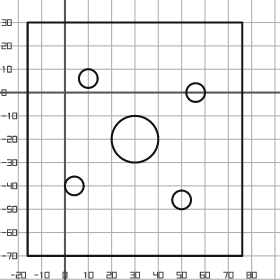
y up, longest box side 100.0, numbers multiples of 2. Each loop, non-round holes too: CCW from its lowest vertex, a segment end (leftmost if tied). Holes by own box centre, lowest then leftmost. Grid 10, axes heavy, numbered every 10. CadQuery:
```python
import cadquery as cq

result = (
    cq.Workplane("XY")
    .moveTo(-16.0, -70.0)
    .lineTo(76.0, -70.0)
    .lineTo(76.0, 30.0)
    .lineTo(-16.0, 30.0)
    .close()
    .moveTo(50.0, -46.0)
    .circle(4.0)
    .moveTo(4.0, -40.0)
    .circle(4.0)
    .moveTo(30.0, -20.0)
    .circle(10.0)
    .moveTo(56.0, 0.0)
    .circle(4.0)
    .moveTo(10.0, 6.0)
    .circle(4.0)
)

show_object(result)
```